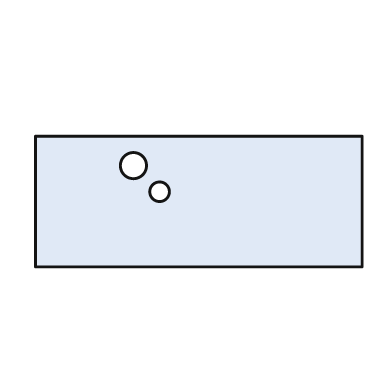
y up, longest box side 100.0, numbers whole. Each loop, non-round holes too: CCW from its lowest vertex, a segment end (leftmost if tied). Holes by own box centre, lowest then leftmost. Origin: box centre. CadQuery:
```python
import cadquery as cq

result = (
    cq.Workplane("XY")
    .moveTo(-50.0, -20.0)
    .lineTo(50.0, -20.0)
    .lineTo(50.0, 20.0)
    .lineTo(-50.0, 20.0)
    .close()
    .moveTo(-12.0, 3.0)
    .circle(3.0)
    .moveTo(-20.0, 11.0)
    .circle(4.0)
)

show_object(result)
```